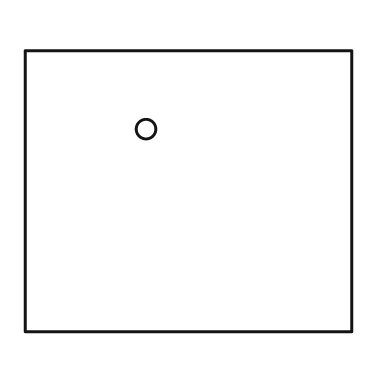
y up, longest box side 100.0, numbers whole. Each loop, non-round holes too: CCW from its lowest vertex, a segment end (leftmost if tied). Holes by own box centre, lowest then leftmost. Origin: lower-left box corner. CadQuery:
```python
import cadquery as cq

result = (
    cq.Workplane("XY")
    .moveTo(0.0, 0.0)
    .lineTo(100.0, 0.0)
    .lineTo(100.0, 86.0)
    .lineTo(0.0, 86.0)
    .close()
    .moveTo(37.0, 62.0)
    .circle(3.0)
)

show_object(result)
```